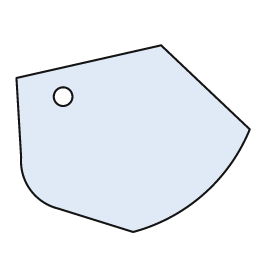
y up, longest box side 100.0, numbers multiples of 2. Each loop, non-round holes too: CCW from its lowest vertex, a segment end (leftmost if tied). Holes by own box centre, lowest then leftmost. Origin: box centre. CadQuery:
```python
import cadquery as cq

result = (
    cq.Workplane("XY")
    .moveTo(0.0, -40.0)
    .threePointArc((30.0, -24.0), (50.0, 4.0))
    .lineTo(12.0, 40.0)
    .lineTo(-50.0, 26.0)
    .lineTo(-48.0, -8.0)
    .threePointArc((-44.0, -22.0), (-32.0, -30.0))
    .close()
    .moveTo(-30.0, 18.0)
    .circle(4.0)
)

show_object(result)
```